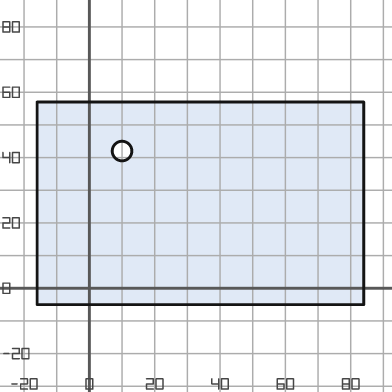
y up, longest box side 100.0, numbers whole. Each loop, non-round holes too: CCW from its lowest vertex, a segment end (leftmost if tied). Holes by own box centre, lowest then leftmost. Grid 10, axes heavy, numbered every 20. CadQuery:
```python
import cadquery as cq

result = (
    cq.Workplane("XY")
    .moveTo(-16.0, -5.0)
    .lineTo(84.0, -5.0)
    .lineTo(84.0, 57.0)
    .lineTo(-16.0, 57.0)
    .close()
    .moveTo(10.0, 42.0)
    .circle(3.0)
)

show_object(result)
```